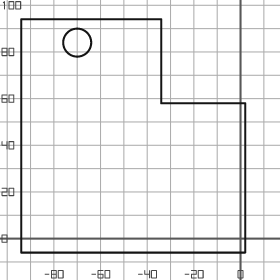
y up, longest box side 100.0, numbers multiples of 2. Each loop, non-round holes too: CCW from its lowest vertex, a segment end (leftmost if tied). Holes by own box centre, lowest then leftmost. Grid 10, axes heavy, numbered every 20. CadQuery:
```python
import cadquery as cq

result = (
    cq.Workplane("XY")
    .moveTo(-94.0, -6.0)
    .lineTo(2.0, -6.0)
    .lineTo(2.0, 58.0)
    .lineTo(-34.0, 58.0)
    .lineTo(-34.0, 94.0)
    .lineTo(-94.0, 94.0)
    .close()
    .moveTo(-70.0, 84.0)
    .circle(6.0)
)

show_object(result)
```